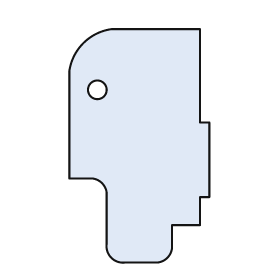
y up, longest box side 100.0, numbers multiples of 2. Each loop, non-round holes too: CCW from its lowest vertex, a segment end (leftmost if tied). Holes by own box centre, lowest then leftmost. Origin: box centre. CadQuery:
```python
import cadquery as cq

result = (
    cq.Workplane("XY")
    .moveTo(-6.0, -50.0)
    .lineTo(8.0, -50.0)
    .threePointArc((12.0, -48.0), (14.0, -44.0))
    .lineTo(14.0, -34.0)
    .lineTo(26.0, -34.0)
    .lineTo(26.0, -22.0)
    .lineTo(30.0, -22.0)
    .lineTo(30.0, 10.0)
    .lineTo(26.0, 10.0)
    .lineTo(26.0, 50.0)
    .lineTo(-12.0, 50.0)
    .threePointArc((-24.0, 44.0), (-30.0, 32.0))
    .lineTo(-30.0, -14.0)
    .lineTo(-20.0, -14.0)
    .threePointArc((-16.0, -16.0), (-14.0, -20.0))
    .lineTo(-14.0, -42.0)
    .threePointArc((-12.0, -48.0), (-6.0, -50.0))
    .close()
    .moveTo(-18.0, 24.0)
    .circle(4.0)
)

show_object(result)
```